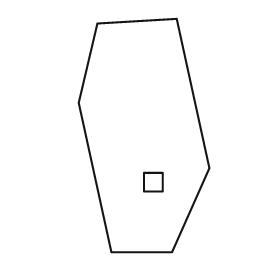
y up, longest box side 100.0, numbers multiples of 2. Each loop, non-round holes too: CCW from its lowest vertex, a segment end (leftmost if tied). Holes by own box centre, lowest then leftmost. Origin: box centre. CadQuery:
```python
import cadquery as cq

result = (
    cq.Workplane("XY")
    .moveTo(-14.0, -50.0)
    .lineTo(12.0, -50.0)
    .lineTo(28.0, -14.0)
    .lineTo(14.0, 50.0)
    .lineTo(-20.0, 48.0)
    .lineTo(-28.0, 14.0)
    .close()
    .moveTo(0.0, -24.0)
    .lineTo(8.0, -24.0)
    .lineTo(8.0, -16.0)
    .lineTo(0.0, -16.0)
    .close()
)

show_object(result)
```